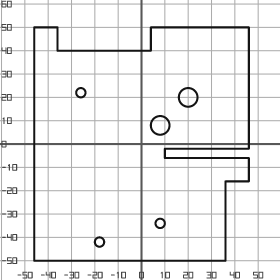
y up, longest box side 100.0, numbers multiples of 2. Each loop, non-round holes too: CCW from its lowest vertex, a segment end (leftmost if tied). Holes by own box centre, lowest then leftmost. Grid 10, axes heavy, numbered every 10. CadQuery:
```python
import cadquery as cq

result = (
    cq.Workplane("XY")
    .moveTo(-46.0, -50.0)
    .lineTo(36.0, -50.0)
    .lineTo(36.0, -16.0)
    .lineTo(46.0, -16.0)
    .lineTo(46.0, -6.0)
    .lineTo(10.0, -6.0)
    .lineTo(10.0, -2.0)
    .lineTo(46.0, -2.0)
    .lineTo(46.0, 50.0)
    .lineTo(4.0, 50.0)
    .lineTo(4.0, 40.0)
    .lineTo(-36.0, 40.0)
    .lineTo(-36.0, 50.0)
    .lineTo(-46.0, 50.0)
    .close()
    .moveTo(-18.0, -42.0)
    .circle(2.0)
    .moveTo(8.0, -34.0)
    .circle(2.0)
    .moveTo(8.0, 8.0)
    .circle(4.0)
    .moveTo(20.0, 20.0)
    .circle(4.0)
    .moveTo(-26.0, 22.0)
    .circle(2.0)
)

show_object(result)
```